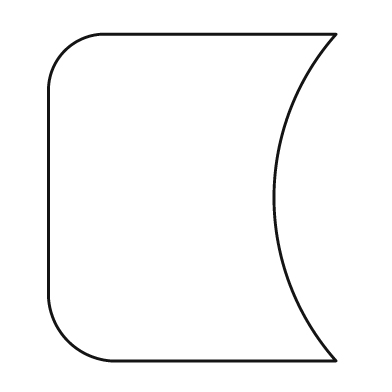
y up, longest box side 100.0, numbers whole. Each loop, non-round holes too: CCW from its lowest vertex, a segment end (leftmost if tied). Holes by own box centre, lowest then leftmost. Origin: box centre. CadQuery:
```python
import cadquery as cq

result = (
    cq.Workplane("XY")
    .moveTo(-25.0, -50.0)
    .lineTo(44.0, -50.0)
    .threePointArc((25.0, 0.0), (44.0, 50.0))
    .lineTo(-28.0, 50.0)
    .threePointArc((-39.0, 45.0), (-44.0, 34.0))
    .lineTo(-44.0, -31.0)
    .threePointArc((-38.0, -44.0), (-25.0, -50.0))
    .close()
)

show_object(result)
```